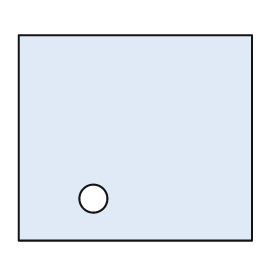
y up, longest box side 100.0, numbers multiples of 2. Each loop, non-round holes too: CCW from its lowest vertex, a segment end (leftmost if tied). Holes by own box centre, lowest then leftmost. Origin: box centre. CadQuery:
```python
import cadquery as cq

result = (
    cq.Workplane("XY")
    .moveTo(-50.0, -44.0)
    .lineTo(50.0, -44.0)
    .lineTo(50.0, 44.0)
    .lineTo(-50.0, 44.0)
    .close()
    .moveTo(-18.0, -26.0)
    .circle(6.0)
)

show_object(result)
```